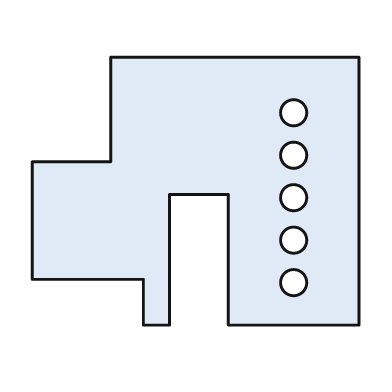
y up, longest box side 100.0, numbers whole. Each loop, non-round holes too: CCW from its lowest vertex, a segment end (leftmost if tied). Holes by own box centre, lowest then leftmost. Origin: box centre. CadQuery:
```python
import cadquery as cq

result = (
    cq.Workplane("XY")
    .moveTo(-16.0, -41.0)
    .lineTo(-8.0, -41.0)
    .lineTo(-8.0, -1.0)
    .lineTo(10.0, -1.0)
    .lineTo(10.0, -41.0)
    .lineTo(50.0, -41.0)
    .lineTo(50.0, 41.0)
    .lineTo(-26.0, 41.0)
    .lineTo(-26.0, 9.0)
    .lineTo(-50.0, 9.0)
    .lineTo(-50.0, -27.0)
    .lineTo(-16.0, -27.0)
    .close()
    .moveTo(30.0, -28.0)
    .circle(4.0)
    .moveTo(30.0, -15.0)
    .circle(4.0)
    .moveTo(30.0, -2.0)
    .circle(4.0)
    .moveTo(30.0, 11.0)
    .circle(4.0)
    .moveTo(30.0, 24.0)
    .circle(4.0)
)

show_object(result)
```